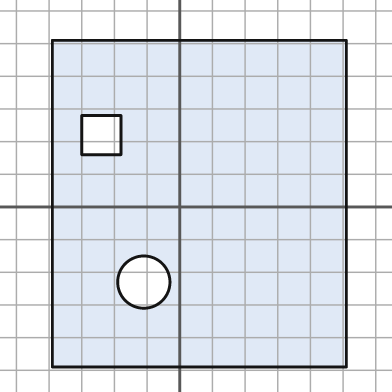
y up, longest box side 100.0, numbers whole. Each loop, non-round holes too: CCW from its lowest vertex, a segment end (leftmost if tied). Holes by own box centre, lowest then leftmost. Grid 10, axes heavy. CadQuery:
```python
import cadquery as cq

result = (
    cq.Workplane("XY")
    .moveTo(-39.0, -49.0)
    .lineTo(51.0, -49.0)
    .lineTo(51.0, 51.0)
    .lineTo(-39.0, 51.0)
    .close()
    .moveTo(-11.0, -23.0)
    .circle(8.0)
    .moveTo(-30.0, 16.0)
    .lineTo(-18.0, 16.0)
    .lineTo(-18.0, 28.0)
    .lineTo(-30.0, 28.0)
    .close()
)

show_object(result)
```